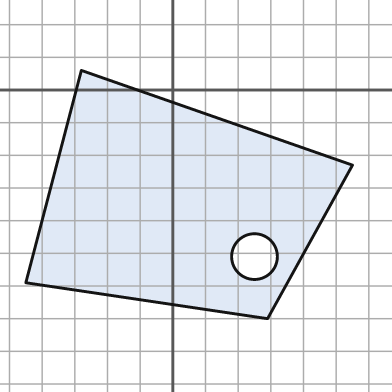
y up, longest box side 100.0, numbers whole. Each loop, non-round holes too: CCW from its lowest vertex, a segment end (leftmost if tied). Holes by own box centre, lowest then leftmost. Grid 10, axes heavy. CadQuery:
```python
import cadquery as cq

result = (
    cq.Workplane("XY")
    .moveTo(29.0, -70.0)
    .lineTo(55.0, -23.0)
    .lineTo(-28.0, 6.0)
    .lineTo(-45.0, -59.0)
    .close()
    .moveTo(25.0, -51.0)
    .circle(7.0)
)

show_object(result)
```